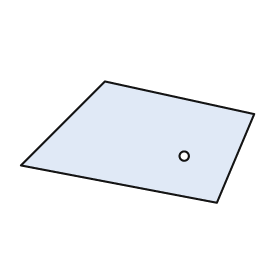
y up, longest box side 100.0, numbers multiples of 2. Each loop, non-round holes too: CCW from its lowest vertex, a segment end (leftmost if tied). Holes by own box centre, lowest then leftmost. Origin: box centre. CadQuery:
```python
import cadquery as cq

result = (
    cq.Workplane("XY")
    .moveTo(34.0, -26.0)
    .lineTo(50.0, 12.0)
    .lineTo(-14.0, 26.0)
    .lineTo(-50.0, -10.0)
    .close()
    .moveTo(20.0, -6.0)
    .circle(2.0)
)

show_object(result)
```